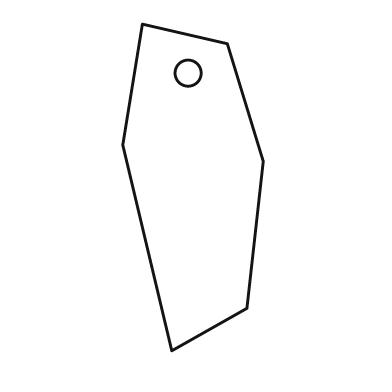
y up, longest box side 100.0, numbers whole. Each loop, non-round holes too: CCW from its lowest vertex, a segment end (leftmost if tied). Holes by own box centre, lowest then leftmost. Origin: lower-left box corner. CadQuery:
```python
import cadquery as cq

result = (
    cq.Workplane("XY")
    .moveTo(15.0, 0.0)
    .lineTo(38.0, 13.0)
    .lineTo(43.0, 58.0)
    .lineTo(32.0, 94.0)
    .lineTo(6.0, 100.0)
    .lineTo(0.0, 63.0)
    .close()
    .moveTo(20.0, 85.0)
    .circle(4.0)
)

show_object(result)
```